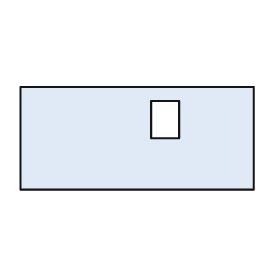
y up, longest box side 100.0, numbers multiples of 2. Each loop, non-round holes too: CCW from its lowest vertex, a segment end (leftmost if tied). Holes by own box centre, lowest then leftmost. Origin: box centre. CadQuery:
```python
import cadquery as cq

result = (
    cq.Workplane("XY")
    .moveTo(-50.0, -22.0)
    .lineTo(50.0, -22.0)
    .lineTo(50.0, 22.0)
    .lineTo(-50.0, 22.0)
    .close()
    .moveTo(6.0, 0.0)
    .lineTo(18.0, 0.0)
    .lineTo(18.0, 16.0)
    .lineTo(6.0, 16.0)
    .close()
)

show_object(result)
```